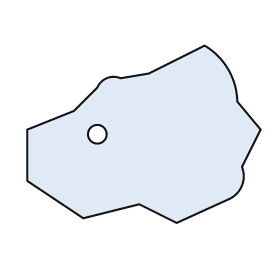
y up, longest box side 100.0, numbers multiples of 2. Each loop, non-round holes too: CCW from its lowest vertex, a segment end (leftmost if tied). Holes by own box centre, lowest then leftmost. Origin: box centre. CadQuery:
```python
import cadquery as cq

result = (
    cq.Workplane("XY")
    .moveTo(14.0, -38.0)
    .lineTo(36.0, -28.0)
    .threePointArc((42.0, -22.0), (42.0, -14.0))
    .lineTo(50.0, 2.0)
    .lineTo(40.0, 14.0)
    .threePointArc((36.0, 28.0), (26.0, 38.0))
    .lineTo(2.0, 26.0)
    .lineTo(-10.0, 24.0)
    .threePointArc((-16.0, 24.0), (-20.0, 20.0))
    .lineTo(-30.0, 10.0)
    .lineTo(-50.0, 2.0)
    .lineTo(-50.0, -20.0)
    .lineTo(-26.0, -36.0)
    .lineTo(-2.0, -30.0)
    .close()
    .moveTo(-20.0, 0.0)
    .circle(4.0)
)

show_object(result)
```